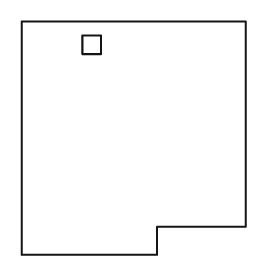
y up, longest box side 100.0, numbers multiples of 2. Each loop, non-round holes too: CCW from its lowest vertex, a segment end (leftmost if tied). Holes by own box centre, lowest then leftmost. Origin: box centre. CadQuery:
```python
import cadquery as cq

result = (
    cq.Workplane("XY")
    .moveTo(-48.0, -50.0)
    .lineTo(10.0, -50.0)
    .lineTo(10.0, -38.0)
    .lineTo(48.0, -38.0)
    .lineTo(48.0, 50.0)
    .lineTo(-48.0, 50.0)
    .close()
    .moveTo(-22.0, 36.0)
    .lineTo(-14.0, 36.0)
    .lineTo(-14.0, 44.0)
    .lineTo(-22.0, 44.0)
    .close()
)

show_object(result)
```